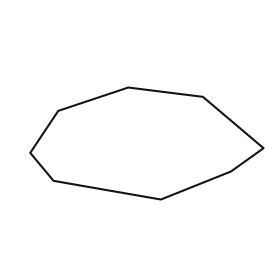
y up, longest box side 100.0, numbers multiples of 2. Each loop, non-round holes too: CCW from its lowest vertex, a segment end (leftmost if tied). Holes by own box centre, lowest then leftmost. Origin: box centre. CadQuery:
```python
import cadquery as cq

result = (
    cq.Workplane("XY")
    .moveTo(6.0, -24.0)
    .lineTo(36.0, -12.0)
    .lineTo(50.0, -2.0)
    .lineTo(24.0, 20.0)
    .lineTo(-8.0, 24.0)
    .lineTo(-38.0, 14.0)
    .lineTo(-50.0, -4.0)
    .lineTo(-40.0, -16.0)
    .close()
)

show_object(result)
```